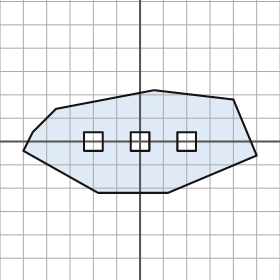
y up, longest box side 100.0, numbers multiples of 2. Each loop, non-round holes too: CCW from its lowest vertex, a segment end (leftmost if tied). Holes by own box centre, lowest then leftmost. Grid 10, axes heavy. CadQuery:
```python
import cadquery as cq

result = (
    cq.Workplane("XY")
    .moveTo(-18.0, -22.0)
    .lineTo(12.0, -22.0)
    .lineTo(50.0, -6.0)
    .lineTo(40.0, 18.0)
    .lineTo(6.0, 22.0)
    .lineTo(-36.0, 14.0)
    .lineTo(-46.0, 4.0)
    .lineTo(-50.0, -4.0)
    .close()
    .moveTo(-24.0, -4.0)
    .lineTo(-16.0, -4.0)
    .lineTo(-16.0, 4.0)
    .lineTo(-24.0, 4.0)
    .close()
    .moveTo(-4.0, -4.0)
    .lineTo(4.0, -4.0)
    .lineTo(4.0, 4.0)
    .lineTo(-4.0, 4.0)
    .close()
    .moveTo(16.0, -4.0)
    .lineTo(24.0, -4.0)
    .lineTo(24.0, 4.0)
    .lineTo(16.0, 4.0)
    .close()
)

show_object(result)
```